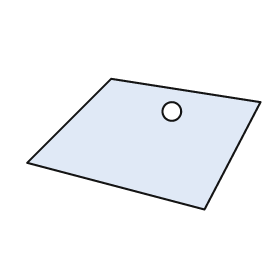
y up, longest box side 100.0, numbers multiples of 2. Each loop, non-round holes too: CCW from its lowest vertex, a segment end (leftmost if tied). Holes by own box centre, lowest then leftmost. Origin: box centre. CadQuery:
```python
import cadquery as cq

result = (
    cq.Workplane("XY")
    .moveTo(26.0, -28.0)
    .lineTo(50.0, 18.0)
    .lineTo(-14.0, 28.0)
    .lineTo(-50.0, -8.0)
    .close()
    .moveTo(12.0, 14.0)
    .circle(4.0)
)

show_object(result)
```